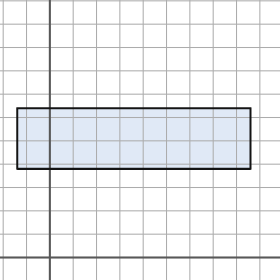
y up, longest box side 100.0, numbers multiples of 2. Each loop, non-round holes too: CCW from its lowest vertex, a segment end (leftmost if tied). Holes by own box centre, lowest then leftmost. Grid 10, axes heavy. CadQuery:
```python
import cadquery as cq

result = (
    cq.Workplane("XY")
    .moveTo(-14.0, 38.0)
    .lineTo(86.0, 38.0)
    .lineTo(86.0, 64.0)
    .lineTo(-14.0, 64.0)
    .close()
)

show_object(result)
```